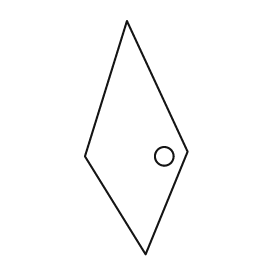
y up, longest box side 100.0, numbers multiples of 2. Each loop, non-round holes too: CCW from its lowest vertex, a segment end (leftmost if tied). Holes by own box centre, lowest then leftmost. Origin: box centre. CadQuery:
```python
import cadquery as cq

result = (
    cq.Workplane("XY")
    .moveTo(4.0, -50.0)
    .lineTo(22.0, -6.0)
    .lineTo(-4.0, 50.0)
    .lineTo(-22.0, -8.0)
    .close()
    .moveTo(12.0, -8.0)
    .circle(4.0)
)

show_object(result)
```